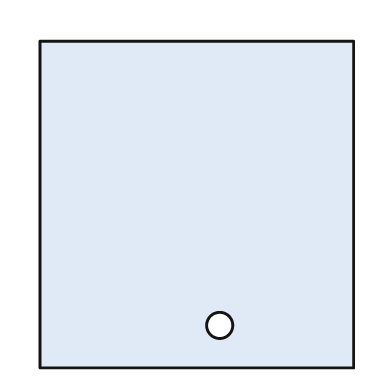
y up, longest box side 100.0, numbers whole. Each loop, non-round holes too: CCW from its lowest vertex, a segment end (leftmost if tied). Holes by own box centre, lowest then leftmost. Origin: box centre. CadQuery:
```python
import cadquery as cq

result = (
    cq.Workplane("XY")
    .moveTo(-48.0, -50.0)
    .lineTo(48.0, -50.0)
    .lineTo(48.0, 50.0)
    .lineTo(-48.0, 50.0)
    .close()
    .moveTo(7.0, -37.0)
    .circle(4.0)
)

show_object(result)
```